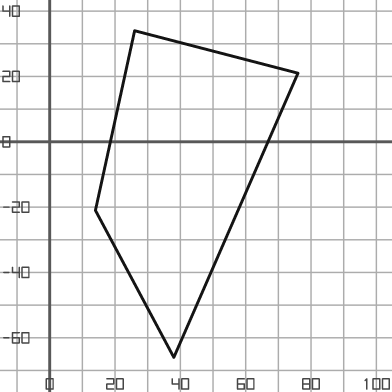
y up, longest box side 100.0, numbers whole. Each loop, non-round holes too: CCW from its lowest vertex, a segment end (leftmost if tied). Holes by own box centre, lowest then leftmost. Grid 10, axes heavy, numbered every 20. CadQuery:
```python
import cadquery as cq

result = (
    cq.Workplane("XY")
    .moveTo(38.0, -66.0)
    .lineTo(76.0, 21.0)
    .lineTo(26.0, 34.0)
    .lineTo(14.0, -21.0)
    .close()
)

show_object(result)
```